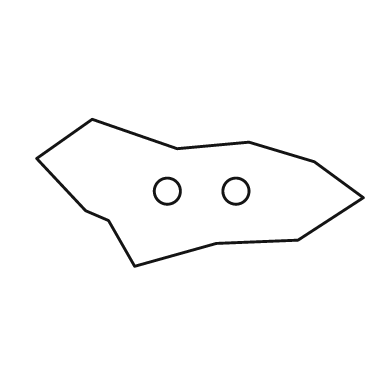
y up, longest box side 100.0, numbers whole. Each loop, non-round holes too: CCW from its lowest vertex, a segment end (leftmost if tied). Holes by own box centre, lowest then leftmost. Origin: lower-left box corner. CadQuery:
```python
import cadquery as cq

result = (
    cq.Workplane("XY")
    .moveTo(30.0, 0.0)
    .lineTo(55.0, 7.0)
    .lineTo(80.0, 8.0)
    .lineTo(100.0, 21.0)
    .lineTo(85.0, 32.0)
    .lineTo(65.0, 38.0)
    .lineTo(43.0, 36.0)
    .lineTo(17.0, 45.0)
    .lineTo(0.0, 33.0)
    .lineTo(15.0, 17.0)
    .lineTo(22.0, 14.0)
    .close()
    .moveTo(40.0, 23.0)
    .circle(4.0)
    .moveTo(61.0, 23.0)
    .circle(4.0)
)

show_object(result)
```